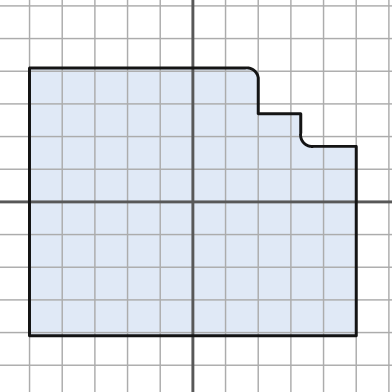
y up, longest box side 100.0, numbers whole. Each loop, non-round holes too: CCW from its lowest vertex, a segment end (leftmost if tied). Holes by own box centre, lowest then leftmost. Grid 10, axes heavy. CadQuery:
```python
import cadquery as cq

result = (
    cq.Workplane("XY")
    .moveTo(-50.0, -41.0)
    .lineTo(50.0, -41.0)
    .lineTo(50.0, 17.0)
    .lineTo(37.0, 17.0)
    .threePointArc((34.0, 18.0), (33.0, 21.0))
    .lineTo(33.0, 27.0)
    .lineTo(20.0, 27.0)
    .lineTo(20.0, 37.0)
    .threePointArc((19.0, 40.0), (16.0, 41.0))
    .lineTo(-50.0, 41.0)
    .close()
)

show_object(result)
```